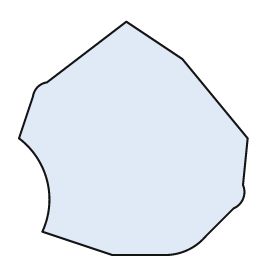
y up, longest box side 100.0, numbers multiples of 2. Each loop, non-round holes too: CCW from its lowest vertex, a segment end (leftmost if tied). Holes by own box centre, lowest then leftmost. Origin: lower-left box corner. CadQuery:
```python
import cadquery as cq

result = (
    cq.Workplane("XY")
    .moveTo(40.0, 0.0)
    .lineTo(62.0, 0.0)
    .threePointArc((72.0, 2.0), (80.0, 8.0))
    .lineTo(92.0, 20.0)
    .threePointArc((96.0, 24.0), (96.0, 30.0))
    .lineTo(98.0, 50.0)
    .lineTo(70.0, 84.0)
    .lineTo(46.0, 100.0)
    .lineTo(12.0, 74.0)
    .threePointArc((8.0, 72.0), (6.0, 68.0))
    .lineTo(0.0, 50.0)
    .threePointArc((12.0, 32.0), (10.0, 10.0))
    .close()
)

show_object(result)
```